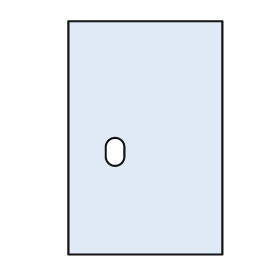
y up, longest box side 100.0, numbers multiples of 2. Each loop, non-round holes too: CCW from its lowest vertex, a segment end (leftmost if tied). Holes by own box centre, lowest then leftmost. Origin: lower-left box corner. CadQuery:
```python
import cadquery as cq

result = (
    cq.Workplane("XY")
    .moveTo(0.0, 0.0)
    .lineTo(66.0, 0.0)
    .lineTo(66.0, 100.0)
    .lineTo(0.0, 100.0)
    .close()
    .moveTo(16.0, 42.0)
    .threePointArc((20.0, 38.0), (24.0, 42.0))
    .lineTo(24.0, 46.0)
    .threePointArc((20.0, 50.0), (16.0, 46.0))
    .close()
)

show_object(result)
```